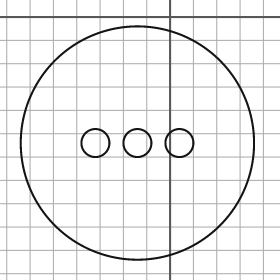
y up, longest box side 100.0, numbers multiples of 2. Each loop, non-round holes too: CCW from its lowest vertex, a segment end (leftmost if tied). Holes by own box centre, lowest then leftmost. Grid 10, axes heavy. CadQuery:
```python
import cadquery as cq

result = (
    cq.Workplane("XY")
    .moveTo(-14.0, -54.0)
    .circle(50.0)
    .moveTo(-32.0, -54.0)
    .circle(6.0)
    .moveTo(-14.0, -54.0)
    .circle(6.0)
    .moveTo(4.0, -54.0)
    .circle(6.0)
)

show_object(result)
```